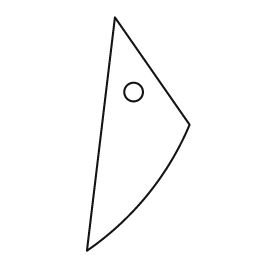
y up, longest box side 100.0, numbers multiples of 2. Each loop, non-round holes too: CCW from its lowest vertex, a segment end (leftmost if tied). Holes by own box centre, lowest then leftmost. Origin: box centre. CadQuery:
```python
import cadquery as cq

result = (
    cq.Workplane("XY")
    .moveTo(-22.0, -50.0)
    .threePointArc((4.0, -26.0), (22.0, 4.0))
    .lineTo(-10.0, 50.0)
    .close()
    .moveTo(-2.0, 18.0)
    .circle(4.0)
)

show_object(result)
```